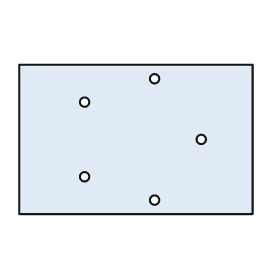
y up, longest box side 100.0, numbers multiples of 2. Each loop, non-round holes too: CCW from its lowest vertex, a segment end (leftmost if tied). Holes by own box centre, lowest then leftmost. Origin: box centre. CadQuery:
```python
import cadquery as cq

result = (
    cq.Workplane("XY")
    .moveTo(-50.0, -32.0)
    .lineTo(50.0, -32.0)
    .lineTo(50.0, 32.0)
    .lineTo(-50.0, 32.0)
    .close()
    .moveTo(8.0, -26.0)
    .circle(2.0)
    .moveTo(-22.0, -16.0)
    .circle(2.0)
    .moveTo(28.0, 0.0)
    .circle(2.0)
    .moveTo(-22.0, 16.0)
    .circle(2.0)
    .moveTo(8.0, 26.0)
    .circle(2.0)
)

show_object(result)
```